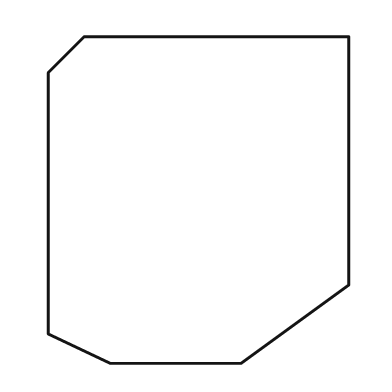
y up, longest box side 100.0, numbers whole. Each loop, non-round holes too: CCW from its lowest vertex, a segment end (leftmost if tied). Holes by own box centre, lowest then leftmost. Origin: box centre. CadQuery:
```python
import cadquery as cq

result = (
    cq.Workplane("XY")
    .moveTo(-27.0, -50.0)
    .lineTo(13.0, -50.0)
    .lineTo(46.0, -26.0)
    .lineTo(46.0, 50.0)
    .lineTo(-35.0, 50.0)
    .lineTo(-46.0, 39.0)
    .lineTo(-46.0, -41.0)
    .close()
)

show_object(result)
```